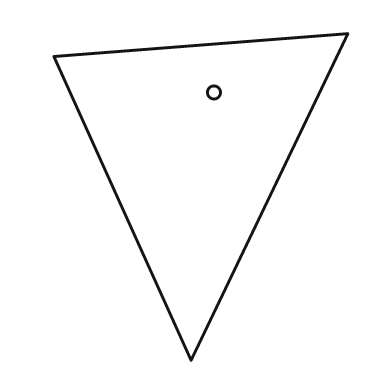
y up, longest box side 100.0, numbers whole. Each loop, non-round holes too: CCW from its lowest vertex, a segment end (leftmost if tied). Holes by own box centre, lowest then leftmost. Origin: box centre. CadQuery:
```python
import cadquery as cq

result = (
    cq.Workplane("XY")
    .moveTo(-3.0, -50.0)
    .lineTo(45.0, 50.0)
    .lineTo(-45.0, 43.0)
    .close()
    .moveTo(4.0, 32.0)
    .circle(2.0)
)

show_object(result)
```